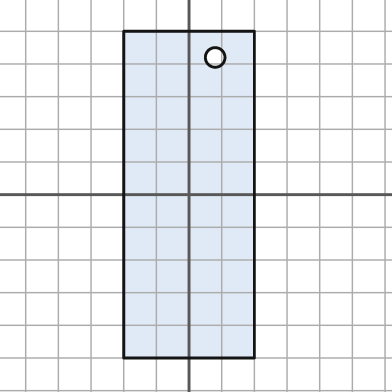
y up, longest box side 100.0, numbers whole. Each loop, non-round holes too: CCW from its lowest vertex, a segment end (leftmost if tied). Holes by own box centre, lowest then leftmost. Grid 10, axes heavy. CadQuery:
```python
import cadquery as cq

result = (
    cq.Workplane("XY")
    .moveTo(-20.0, -50.0)
    .lineTo(20.0, -50.0)
    .lineTo(20.0, 50.0)
    .lineTo(-20.0, 50.0)
    .close()
    .moveTo(8.0, 42.0)
    .circle(3.0)
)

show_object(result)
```